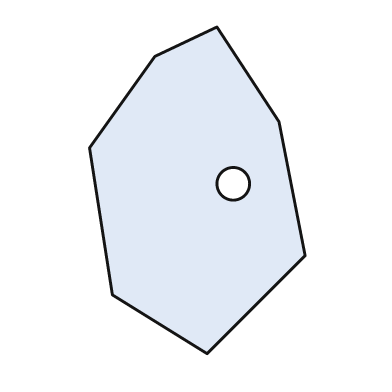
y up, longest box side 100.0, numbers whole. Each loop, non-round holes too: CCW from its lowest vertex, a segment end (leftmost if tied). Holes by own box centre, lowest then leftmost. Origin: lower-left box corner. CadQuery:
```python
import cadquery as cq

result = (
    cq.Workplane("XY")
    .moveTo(36.0, 0.0)
    .lineTo(66.0, 30.0)
    .lineTo(58.0, 71.0)
    .lineTo(39.0, 100.0)
    .lineTo(20.0, 91.0)
    .lineTo(0.0, 63.0)
    .lineTo(7.0, 18.0)
    .close()
    .moveTo(44.0, 52.0)
    .circle(5.0)
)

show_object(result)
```